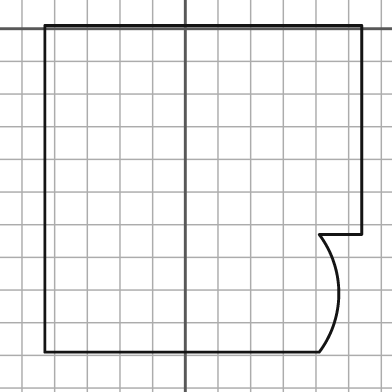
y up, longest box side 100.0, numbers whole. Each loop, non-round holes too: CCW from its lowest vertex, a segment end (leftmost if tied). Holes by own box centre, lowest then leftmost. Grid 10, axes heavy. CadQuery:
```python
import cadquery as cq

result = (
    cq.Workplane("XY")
    .moveTo(-43.0, -99.0)
    .lineTo(41.0, -99.0)
    .threePointArc((47.0, -81.0), (41.0, -63.0))
    .lineTo(54.0, -63.0)
    .lineTo(54.0, 1.0)
    .lineTo(-43.0, 1.0)
    .close()
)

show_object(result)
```